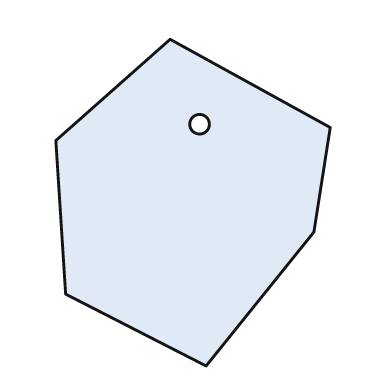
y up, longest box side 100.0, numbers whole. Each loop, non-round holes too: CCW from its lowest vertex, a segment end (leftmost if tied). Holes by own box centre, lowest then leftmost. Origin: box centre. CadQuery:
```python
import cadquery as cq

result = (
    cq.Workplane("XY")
    .moveTo(4.0, -50.0)
    .lineTo(37.0, -9.0)
    .lineTo(42.0, 23.0)
    .lineTo(-7.0, 50.0)
    .lineTo(-42.0, 19.0)
    .lineTo(-39.0, -28.0)
    .close()
    .moveTo(2.0, 24.0)
    .circle(3.0)
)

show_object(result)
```